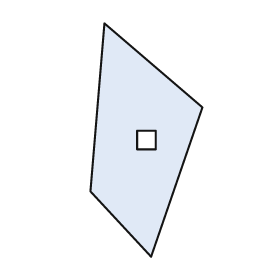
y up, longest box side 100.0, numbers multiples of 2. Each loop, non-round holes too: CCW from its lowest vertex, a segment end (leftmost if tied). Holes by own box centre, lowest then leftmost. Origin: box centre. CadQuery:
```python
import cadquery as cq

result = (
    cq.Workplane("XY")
    .moveTo(2.0, -50.0)
    .lineTo(24.0, 14.0)
    .lineTo(-18.0, 50.0)
    .lineTo(-24.0, -22.0)
    .close()
    .moveTo(-4.0, -4.0)
    .lineTo(4.0, -4.0)
    .lineTo(4.0, 4.0)
    .lineTo(-4.0, 4.0)
    .close()
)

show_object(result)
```